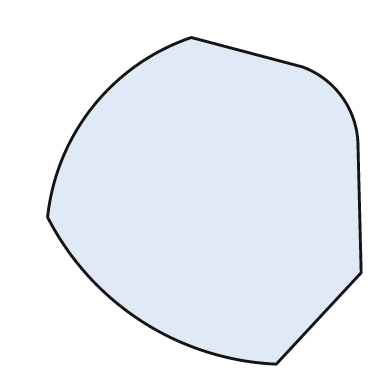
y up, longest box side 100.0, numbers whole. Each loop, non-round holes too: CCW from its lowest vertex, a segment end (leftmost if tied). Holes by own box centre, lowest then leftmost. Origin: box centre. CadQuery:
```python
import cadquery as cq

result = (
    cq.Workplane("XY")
    .moveTo(22.0, -50.0)
    .lineTo(48.0, -22.0)
    .lineTo(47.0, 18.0)
    .threePointArc((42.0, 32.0), (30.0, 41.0))
    .lineTo(-4.0, 50.0)
    .threePointArc((-34.0, 29.0), (-48.0, -5.0))
    .threePointArc((-19.0, -37.0), (22.0, -50.0))
    .close()
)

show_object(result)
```